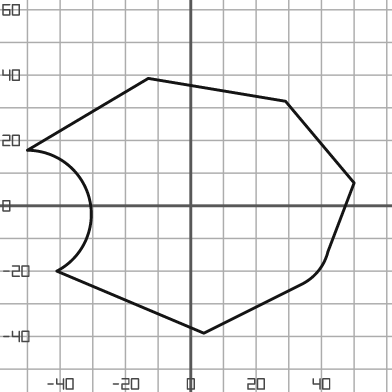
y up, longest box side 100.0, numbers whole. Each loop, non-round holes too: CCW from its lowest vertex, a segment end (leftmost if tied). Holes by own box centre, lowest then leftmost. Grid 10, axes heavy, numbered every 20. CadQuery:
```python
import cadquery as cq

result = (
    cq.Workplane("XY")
    .moveTo(4.0, -39.0)
    .lineTo(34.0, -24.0)
    .threePointArc((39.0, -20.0), (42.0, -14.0))
    .lineTo(50.0, 7.0)
    .lineTo(29.0, 32.0)
    .lineTo(-13.0, 39.0)
    .lineTo(-50.0, 17.0)
    .threePointArc((-31.0, 2.0), (-41.0, -20.0))
    .close()
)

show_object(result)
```